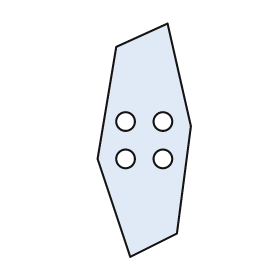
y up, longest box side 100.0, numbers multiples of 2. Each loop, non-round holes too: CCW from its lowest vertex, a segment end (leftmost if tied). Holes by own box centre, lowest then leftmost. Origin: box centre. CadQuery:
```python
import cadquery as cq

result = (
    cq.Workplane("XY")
    .moveTo(-6.0, -50.0)
    .lineTo(14.0, -40.0)
    .lineTo(20.0, 6.0)
    .lineTo(10.0, 50.0)
    .lineTo(-12.0, 40.0)
    .lineTo(-20.0, -8.0)
    .close()
    .moveTo(-8.0, -8.0)
    .circle(4.0)
    .moveTo(8.0, -8.0)
    .circle(4.0)
    .moveTo(-8.0, 8.0)
    .circle(4.0)
    .moveTo(8.0, 8.0)
    .circle(4.0)
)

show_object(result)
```